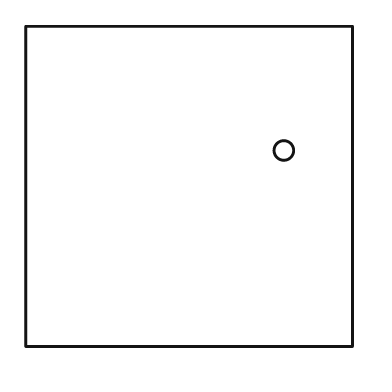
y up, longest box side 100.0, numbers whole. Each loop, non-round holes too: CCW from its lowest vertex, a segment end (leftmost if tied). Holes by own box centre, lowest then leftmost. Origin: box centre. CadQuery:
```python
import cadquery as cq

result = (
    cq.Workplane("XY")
    .moveTo(-50.0, -49.0)
    .lineTo(50.0, -49.0)
    .lineTo(50.0, 49.0)
    .lineTo(-50.0, 49.0)
    .close()
    .moveTo(29.0, 11.0)
    .circle(3.0)
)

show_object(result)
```